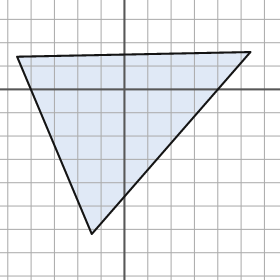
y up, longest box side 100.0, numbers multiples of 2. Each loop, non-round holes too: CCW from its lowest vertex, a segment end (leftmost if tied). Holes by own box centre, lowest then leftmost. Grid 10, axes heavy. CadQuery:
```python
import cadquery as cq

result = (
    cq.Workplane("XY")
    .moveTo(-14.0, -62.0)
    .lineTo(54.0, 16.0)
    .lineTo(-46.0, 14.0)
    .close()
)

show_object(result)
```